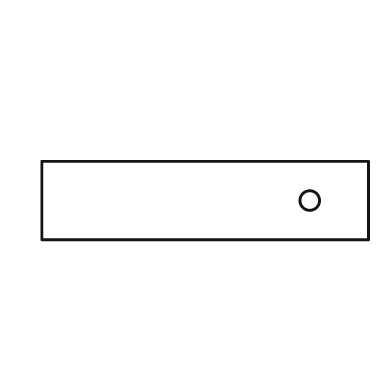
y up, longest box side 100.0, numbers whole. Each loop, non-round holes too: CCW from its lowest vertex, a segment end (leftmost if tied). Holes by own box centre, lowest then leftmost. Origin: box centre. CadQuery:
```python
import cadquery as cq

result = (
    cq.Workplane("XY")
    .moveTo(-50.0, -12.0)
    .lineTo(50.0, -12.0)
    .lineTo(50.0, 12.0)
    .lineTo(-50.0, 12.0)
    .close()
    .moveTo(32.0, 0.0)
    .circle(3.0)
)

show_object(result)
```